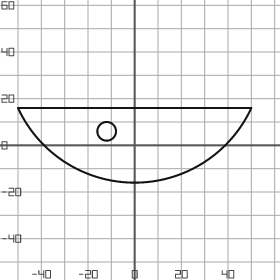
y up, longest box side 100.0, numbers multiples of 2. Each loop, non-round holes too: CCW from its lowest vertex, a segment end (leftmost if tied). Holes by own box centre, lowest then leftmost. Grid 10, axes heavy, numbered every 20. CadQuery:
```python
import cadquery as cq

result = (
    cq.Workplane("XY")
    .moveTo(-50.0, 16.0)
    .threePointArc((0.0, -16.0), (50.0, 16.0))
    .close()
    .moveTo(-12.0, 6.0)
    .circle(4.0)
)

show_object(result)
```